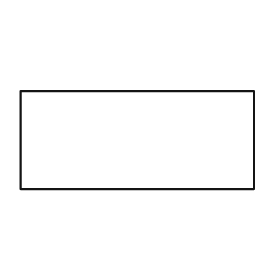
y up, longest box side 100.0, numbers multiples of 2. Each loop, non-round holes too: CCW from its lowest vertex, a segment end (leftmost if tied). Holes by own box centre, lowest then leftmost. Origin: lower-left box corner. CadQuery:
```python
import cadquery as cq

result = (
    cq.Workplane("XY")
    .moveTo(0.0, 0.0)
    .lineTo(100.0, 0.0)
    .lineTo(100.0, 42.0)
    .lineTo(0.0, 42.0)
    .close()
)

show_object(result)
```